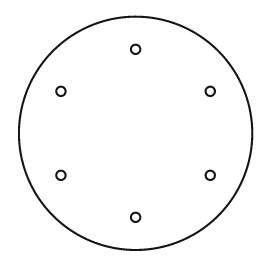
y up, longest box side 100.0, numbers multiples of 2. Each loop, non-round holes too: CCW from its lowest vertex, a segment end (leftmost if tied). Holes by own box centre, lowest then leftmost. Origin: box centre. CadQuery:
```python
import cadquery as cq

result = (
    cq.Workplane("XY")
    .moveTo(0.0, 0.0)
    .circle(50.0)
    .moveTo(0.0, -36.0)
    .circle(2.0)
    .moveTo(-32.0, -18.0)
    .circle(2.0)
    .moveTo(32.0, -18.0)
    .circle(2.0)
    .moveTo(-32.0, 18.0)
    .circle(2.0)
    .moveTo(32.0, 18.0)
    .circle(2.0)
    .moveTo(0.0, 36.0)
    .circle(2.0)
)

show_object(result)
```